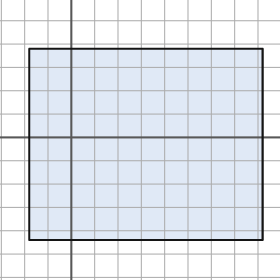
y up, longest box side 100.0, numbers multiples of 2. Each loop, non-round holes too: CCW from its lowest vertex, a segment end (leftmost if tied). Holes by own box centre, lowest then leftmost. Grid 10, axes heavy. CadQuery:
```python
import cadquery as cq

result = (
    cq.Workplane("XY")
    .moveTo(-18.0, -44.0)
    .lineTo(82.0, -44.0)
    .lineTo(82.0, 38.0)
    .lineTo(-18.0, 38.0)
    .close()
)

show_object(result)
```